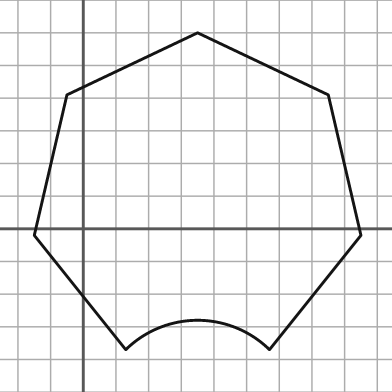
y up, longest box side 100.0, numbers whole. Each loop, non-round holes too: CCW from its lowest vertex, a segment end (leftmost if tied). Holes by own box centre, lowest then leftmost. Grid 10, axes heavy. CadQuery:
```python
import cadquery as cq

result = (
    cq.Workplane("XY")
    .moveTo(13.0, -37.0)
    .threePointArc((35.0, -28.0), (57.0, -37.0))
    .lineTo(85.0, -2.0)
    .lineTo(75.0, 41.0)
    .lineTo(35.0, 60.0)
    .lineTo(-5.0, 41.0)
    .lineTo(-15.0, -2.0)
    .close()
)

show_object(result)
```